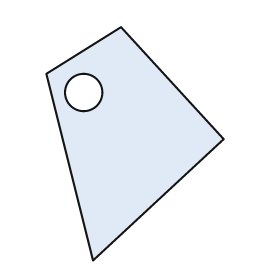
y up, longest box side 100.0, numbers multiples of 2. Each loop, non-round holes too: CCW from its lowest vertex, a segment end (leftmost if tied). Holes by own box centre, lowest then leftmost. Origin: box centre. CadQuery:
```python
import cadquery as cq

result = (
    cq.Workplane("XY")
    .moveTo(-18.0, -50.0)
    .lineTo(38.0, 2.0)
    .lineTo(-6.0, 50.0)
    .lineTo(-38.0, 30.0)
    .close()
    .moveTo(-22.0, 22.0)
    .circle(8.0)
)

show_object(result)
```